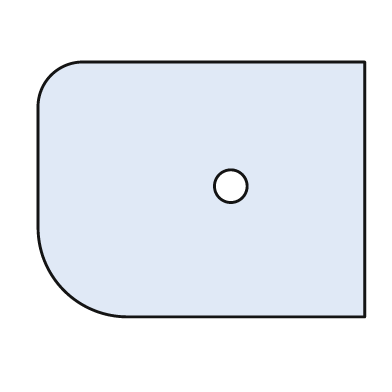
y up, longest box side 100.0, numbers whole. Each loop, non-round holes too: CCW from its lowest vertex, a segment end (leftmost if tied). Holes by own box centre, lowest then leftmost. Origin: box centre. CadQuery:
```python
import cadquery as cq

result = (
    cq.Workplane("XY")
    .moveTo(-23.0, -39.0)
    .lineTo(50.0, -39.0)
    .lineTo(50.0, 39.0)
    .lineTo(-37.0, 39.0)
    .threePointArc((-46.0, 35.0), (-50.0, 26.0))
    .lineTo(-50.0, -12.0)
    .threePointArc((-42.0, -31.0), (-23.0, -39.0))
    .close()
    .moveTo(9.0, 1.0)
    .circle(5.0)
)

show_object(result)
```